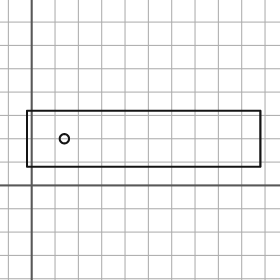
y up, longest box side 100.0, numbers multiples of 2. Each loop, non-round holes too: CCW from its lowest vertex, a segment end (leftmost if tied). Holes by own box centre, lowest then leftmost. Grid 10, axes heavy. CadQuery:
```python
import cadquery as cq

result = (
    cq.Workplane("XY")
    .moveTo(-2.0, 8.0)
    .lineTo(98.0, 8.0)
    .lineTo(98.0, 32.0)
    .lineTo(-2.0, 32.0)
    .close()
    .moveTo(14.0, 20.0)
    .circle(2.0)
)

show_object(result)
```